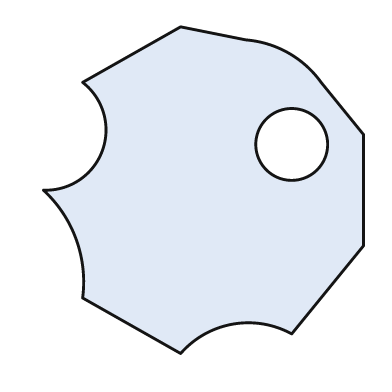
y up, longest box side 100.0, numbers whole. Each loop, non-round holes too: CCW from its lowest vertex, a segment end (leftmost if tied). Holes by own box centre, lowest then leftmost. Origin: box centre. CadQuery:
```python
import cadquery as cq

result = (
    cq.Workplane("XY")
    .moveTo(-7.0, -50.0)
    .threePointArc((9.0, -41.0), (27.0, -44.0))
    .lineTo(49.0, -17.0)
    .lineTo(49.0, 17.0)
    .lineTo(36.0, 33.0)
    .threePointArc((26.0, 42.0), (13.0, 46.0))
    .lineTo(-7.0, 50.0)
    .lineTo(-37.0, 33.0)
    .threePointArc((-31.0, 12.0), (-49.0, 0.0))
    .threePointArc((-39.0, -15.0), (-37.0, -33.0))
    .close()
    .moveTo(27.0, 14.0)
    .circle(11.0)
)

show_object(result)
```